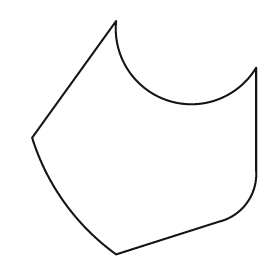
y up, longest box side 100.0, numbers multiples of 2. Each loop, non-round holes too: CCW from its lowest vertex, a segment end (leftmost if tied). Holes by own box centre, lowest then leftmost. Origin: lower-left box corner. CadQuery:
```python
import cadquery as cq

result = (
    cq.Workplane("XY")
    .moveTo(36.0, 0.0)
    .lineTo(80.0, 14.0)
    .threePointArc((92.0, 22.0), (96.0, 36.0))
    .lineTo(96.0, 80.0)
    .threePointArc((58.0, 66.0), (36.0, 100.0))
    .lineTo(0.0, 50.0)
    .threePointArc((14.0, 22.0), (36.0, 0.0))
    .close()
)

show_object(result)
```